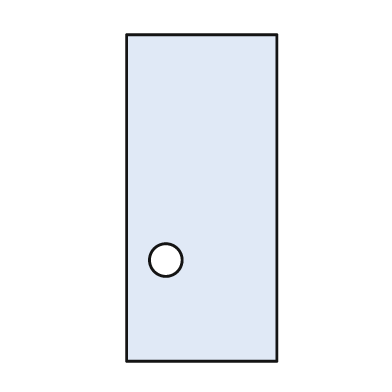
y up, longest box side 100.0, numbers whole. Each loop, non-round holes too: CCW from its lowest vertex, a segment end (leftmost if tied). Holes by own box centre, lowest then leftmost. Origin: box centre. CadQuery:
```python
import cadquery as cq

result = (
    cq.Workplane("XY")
    .moveTo(-23.0, -50.0)
    .lineTo(23.0, -50.0)
    .lineTo(23.0, 50.0)
    .lineTo(-23.0, 50.0)
    .close()
    .moveTo(-11.0, -19.0)
    .circle(5.0)
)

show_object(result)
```